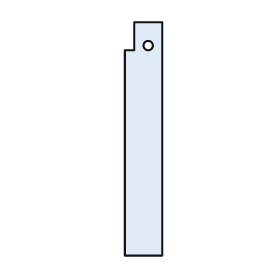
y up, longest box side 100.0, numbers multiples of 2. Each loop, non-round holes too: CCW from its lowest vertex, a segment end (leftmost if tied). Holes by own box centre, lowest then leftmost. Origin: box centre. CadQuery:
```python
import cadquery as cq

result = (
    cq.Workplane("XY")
    .moveTo(-8.0, -50.0)
    .lineTo(8.0, -50.0)
    .lineTo(8.0, 50.0)
    .lineTo(-4.0, 50.0)
    .lineTo(-4.0, 38.0)
    .lineTo(-8.0, 38.0)
    .close()
    .moveTo(2.0, 40.0)
    .circle(2.0)
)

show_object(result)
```